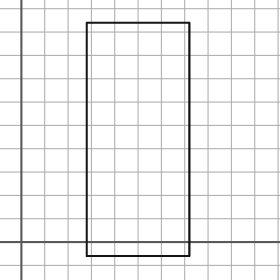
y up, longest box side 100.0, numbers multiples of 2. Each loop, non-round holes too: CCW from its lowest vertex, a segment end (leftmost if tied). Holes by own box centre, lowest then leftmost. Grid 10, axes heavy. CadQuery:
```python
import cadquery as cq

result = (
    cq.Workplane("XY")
    .moveTo(28.0, -6.0)
    .lineTo(72.0, -6.0)
    .lineTo(72.0, 94.0)
    .lineTo(28.0, 94.0)
    .close()
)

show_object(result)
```